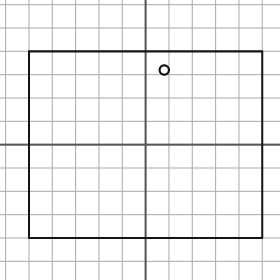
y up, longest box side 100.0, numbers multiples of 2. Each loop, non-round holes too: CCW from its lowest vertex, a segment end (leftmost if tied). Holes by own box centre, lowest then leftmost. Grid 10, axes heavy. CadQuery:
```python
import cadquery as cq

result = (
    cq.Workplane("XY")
    .moveTo(-50.0, -40.0)
    .lineTo(50.0, -40.0)
    .lineTo(50.0, 40.0)
    .lineTo(-50.0, 40.0)
    .close()
    .moveTo(8.0, 32.0)
    .circle(2.0)
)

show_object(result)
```